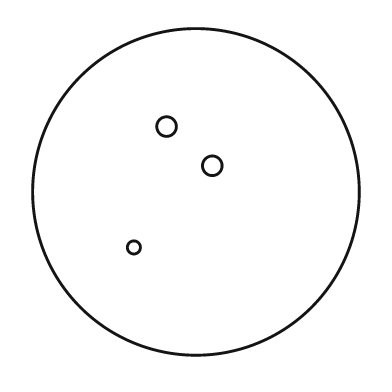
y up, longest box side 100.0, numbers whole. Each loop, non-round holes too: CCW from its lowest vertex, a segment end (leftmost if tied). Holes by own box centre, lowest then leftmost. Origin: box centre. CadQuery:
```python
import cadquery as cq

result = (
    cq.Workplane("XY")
    .moveTo(0.0, 0.0)
    .circle(50.0)
    .moveTo(-19.0, -17.0)
    .circle(2.0)
    .moveTo(5.0, 8.0)
    .circle(3.0)
    .moveTo(-9.0, 20.0)
    .circle(3.0)
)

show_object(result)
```